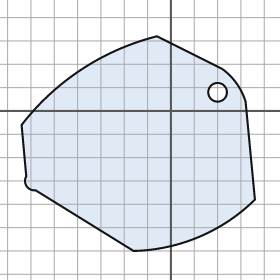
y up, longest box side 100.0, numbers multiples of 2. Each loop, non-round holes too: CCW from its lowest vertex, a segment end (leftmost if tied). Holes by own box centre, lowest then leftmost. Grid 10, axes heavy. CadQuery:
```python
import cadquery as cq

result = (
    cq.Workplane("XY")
    .moveTo(-16.0, -60.0)
    .threePointArc((12.0, -54.0), (36.0, -38.0))
    .lineTo(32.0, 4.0)
    .threePointArc((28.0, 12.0), (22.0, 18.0))
    .lineTo(-6.0, 32.0)
    .threePointArc((-38.0, 18.0), (-64.0, -6.0))
    .lineTo(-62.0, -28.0)
    .threePointArc((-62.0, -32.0), (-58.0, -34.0))
    .close()
    .moveTo(20.0, 8.0)
    .circle(4.0)
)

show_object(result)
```